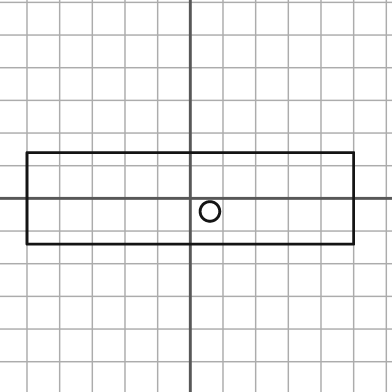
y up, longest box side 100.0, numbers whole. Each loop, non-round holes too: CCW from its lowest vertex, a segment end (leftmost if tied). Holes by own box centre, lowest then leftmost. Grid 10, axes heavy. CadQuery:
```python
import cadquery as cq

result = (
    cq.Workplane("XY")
    .moveTo(-50.0, -14.0)
    .lineTo(50.0, -14.0)
    .lineTo(50.0, 14.0)
    .lineTo(-50.0, 14.0)
    .close()
    .moveTo(6.0, -4.0)
    .circle(3.0)
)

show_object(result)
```